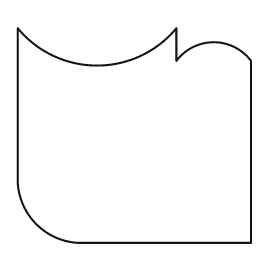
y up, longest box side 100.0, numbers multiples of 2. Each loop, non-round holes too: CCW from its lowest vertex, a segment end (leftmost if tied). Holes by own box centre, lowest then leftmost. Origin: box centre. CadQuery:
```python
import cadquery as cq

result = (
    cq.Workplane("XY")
    .moveTo(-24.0, -46.0)
    .lineTo(50.0, -46.0)
    .lineTo(50.0, 32.0)
    .threePointArc((34.0, 40.0), (18.0, 32.0))
    .lineTo(18.0, 46.0)
    .threePointArc((-16.0, 30.0), (-50.0, 46.0))
    .lineTo(-50.0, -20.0)
    .threePointArc((-42.0, -38.0), (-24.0, -46.0))
    .close()
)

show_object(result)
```